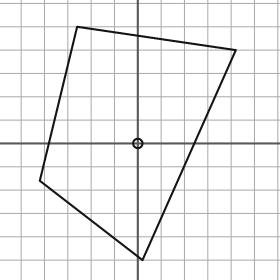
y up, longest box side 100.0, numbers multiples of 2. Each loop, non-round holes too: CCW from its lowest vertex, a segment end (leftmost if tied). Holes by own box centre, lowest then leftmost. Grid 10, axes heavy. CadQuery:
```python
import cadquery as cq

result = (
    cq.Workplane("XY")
    .moveTo(2.0, -50.0)
    .lineTo(42.0, 40.0)
    .lineTo(-26.0, 50.0)
    .lineTo(-42.0, -16.0)
    .close()
    .moveTo(0.0, 0.0)
    .circle(2.0)
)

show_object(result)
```